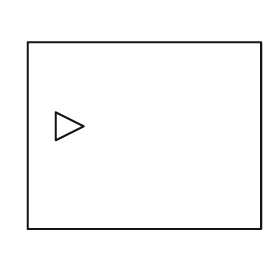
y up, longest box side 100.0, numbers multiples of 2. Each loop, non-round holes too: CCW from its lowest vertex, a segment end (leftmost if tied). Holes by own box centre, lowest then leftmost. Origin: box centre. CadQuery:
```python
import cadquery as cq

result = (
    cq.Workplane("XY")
    .moveTo(-50.0, -40.0)
    .lineTo(50.0, -40.0)
    .lineTo(50.0, 40.0)
    .lineTo(-50.0, 40.0)
    .close()
    .moveTo(-38.0, -2.0)
    .lineTo(-26.0, 4.0)
    .lineTo(-38.0, 10.0)
    .close()
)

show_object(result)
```